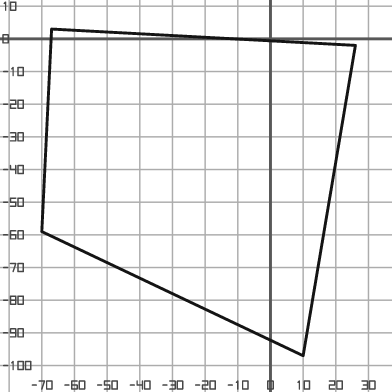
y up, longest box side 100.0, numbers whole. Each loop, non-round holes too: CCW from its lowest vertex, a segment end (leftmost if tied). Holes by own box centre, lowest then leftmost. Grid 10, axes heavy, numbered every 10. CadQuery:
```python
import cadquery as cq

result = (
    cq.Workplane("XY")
    .moveTo(10.0, -97.0)
    .lineTo(26.0, -2.0)
    .lineTo(-67.0, 3.0)
    .lineTo(-70.0, -59.0)
    .close()
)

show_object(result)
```